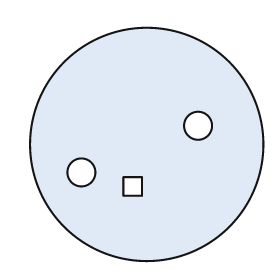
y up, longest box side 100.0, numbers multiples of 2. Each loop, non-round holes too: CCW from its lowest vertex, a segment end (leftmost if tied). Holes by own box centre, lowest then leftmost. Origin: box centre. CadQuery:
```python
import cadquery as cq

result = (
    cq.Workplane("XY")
    .moveTo(0.0, 0.0)
    .circle(50.0)
    .moveTo(-10.0, -22.0)
    .lineTo(-2.0, -22.0)
    .lineTo(-2.0, -14.0)
    .lineTo(-10.0, -14.0)
    .close()
    .moveTo(-28.0, -12.0)
    .circle(6.0)
    .moveTo(22.0, 8.0)
    .circle(6.0)
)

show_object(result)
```